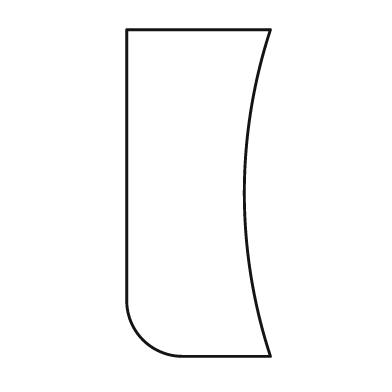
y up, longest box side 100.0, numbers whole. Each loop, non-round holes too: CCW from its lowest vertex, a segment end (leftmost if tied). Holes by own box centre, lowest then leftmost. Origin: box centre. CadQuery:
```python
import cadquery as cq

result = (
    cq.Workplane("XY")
    .moveTo(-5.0, -50.0)
    .lineTo(22.0, -50.0)
    .threePointArc((14.0, 0.0), (22.0, 50.0))
    .lineTo(-22.0, 50.0)
    .lineTo(-22.0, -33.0)
    .threePointArc((-17.0, -45.0), (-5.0, -50.0))
    .close()
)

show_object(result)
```